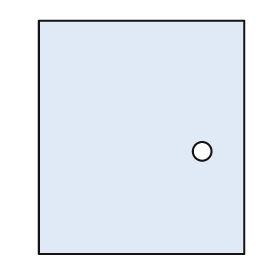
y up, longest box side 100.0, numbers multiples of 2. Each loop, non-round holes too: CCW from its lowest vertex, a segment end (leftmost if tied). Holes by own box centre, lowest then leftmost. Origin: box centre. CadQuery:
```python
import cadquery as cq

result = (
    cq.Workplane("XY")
    .moveTo(-44.0, -50.0)
    .lineTo(44.0, -50.0)
    .lineTo(44.0, 50.0)
    .lineTo(-44.0, 50.0)
    .close()
    .moveTo(26.0, -6.0)
    .circle(4.0)
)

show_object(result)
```